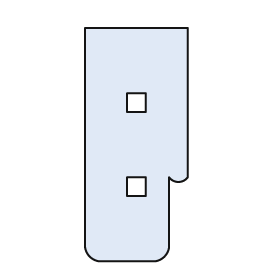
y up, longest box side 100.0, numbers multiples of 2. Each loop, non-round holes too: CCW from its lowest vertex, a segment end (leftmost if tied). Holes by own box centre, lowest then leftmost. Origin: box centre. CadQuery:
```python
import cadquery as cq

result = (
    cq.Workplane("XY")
    .moveTo(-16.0, -50.0)
    .lineTo(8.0, -50.0)
    .threePointArc((12.0, -48.0), (14.0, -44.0))
    .lineTo(14.0, -14.0)
    .threePointArc((18.0, -16.0), (22.0, -14.0))
    .lineTo(22.0, 50.0)
    .lineTo(-22.0, 50.0)
    .lineTo(-22.0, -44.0)
    .threePointArc((-20.0, -48.0), (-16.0, -50.0))
    .close()
    .moveTo(-4.0, -22.0)
    .lineTo(4.0, -22.0)
    .lineTo(4.0, -14.0)
    .lineTo(-4.0, -14.0)
    .close()
    .moveTo(-4.0, 14.0)
    .lineTo(4.0, 14.0)
    .lineTo(4.0, 22.0)
    .lineTo(-4.0, 22.0)
    .close()
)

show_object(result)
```